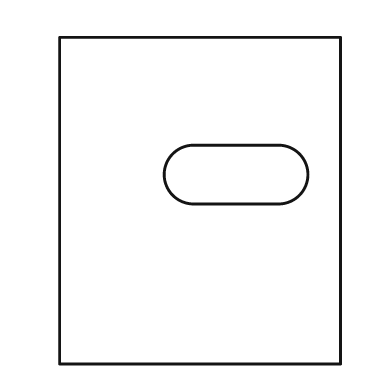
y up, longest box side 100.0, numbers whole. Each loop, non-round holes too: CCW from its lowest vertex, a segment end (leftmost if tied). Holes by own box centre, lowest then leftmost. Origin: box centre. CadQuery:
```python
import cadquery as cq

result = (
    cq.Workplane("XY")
    .moveTo(-43.0, -50.0)
    .lineTo(43.0, -50.0)
    .lineTo(43.0, 50.0)
    .lineTo(-43.0, 50.0)
    .close()
    .moveTo(-2.0, -1.0)
    .lineTo(24.0, -1.0)
    .threePointArc((33.0, 8.0), (24.0, 17.0))
    .lineTo(-2.0, 17.0)
    .threePointArc((-11.0, 8.0), (-2.0, -1.0))
    .close()
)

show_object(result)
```